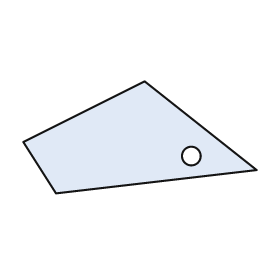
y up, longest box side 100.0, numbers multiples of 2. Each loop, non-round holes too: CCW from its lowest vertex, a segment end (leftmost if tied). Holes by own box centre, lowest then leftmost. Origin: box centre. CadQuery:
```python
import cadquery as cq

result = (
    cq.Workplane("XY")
    .moveTo(-36.0, -24.0)
    .lineTo(50.0, -14.0)
    .lineTo(2.0, 24.0)
    .lineTo(-50.0, -2.0)
    .close()
    .moveTo(22.0, -8.0)
    .circle(4.0)
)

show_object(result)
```